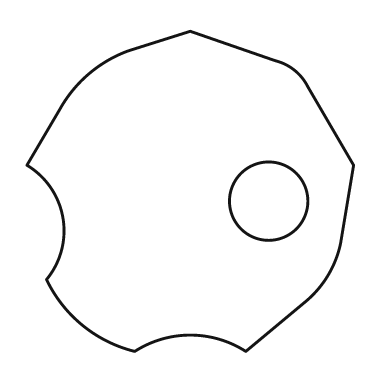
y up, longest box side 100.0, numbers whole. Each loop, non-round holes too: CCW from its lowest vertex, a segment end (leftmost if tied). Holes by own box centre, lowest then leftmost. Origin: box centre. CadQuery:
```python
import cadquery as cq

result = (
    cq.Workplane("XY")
    .moveTo(-17.0, -49.0)
    .threePointArc((0.0, -44.0), (17.0, -49.0))
    .lineTo(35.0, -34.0)
    .threePointArc((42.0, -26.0), (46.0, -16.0))
    .lineTo(50.0, 8.0)
    .lineTo(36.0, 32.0)
    .threePointArc((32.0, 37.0), (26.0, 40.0))
    .lineTo(0.0, 49.0)
    .lineTo(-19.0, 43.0)
    .threePointArc((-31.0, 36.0), (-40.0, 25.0))
    .lineTo(-50.0, 8.0)
    .threePointArc((-39.0, -8.0), (-44.0, -27.0))
    .threePointArc((-33.0, -41.0), (-17.0, -49.0))
    .close()
    .moveTo(24.0, -3.0)
    .circle(12.0)
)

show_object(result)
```